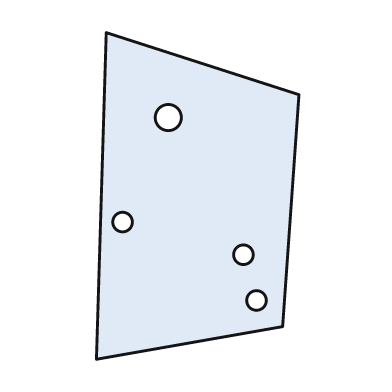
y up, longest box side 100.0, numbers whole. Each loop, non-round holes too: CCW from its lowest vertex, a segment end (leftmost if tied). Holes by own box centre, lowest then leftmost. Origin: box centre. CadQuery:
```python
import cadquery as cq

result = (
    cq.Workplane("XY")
    .moveTo(-31.0, -50.0)
    .lineTo(26.0, -40.0)
    .lineTo(31.0, 31.0)
    .lineTo(-28.0, 50.0)
    .close()
    .moveTo(18.0, -32.0)
    .circle(3.0)
    .moveTo(14.0, -18.0)
    .circle(3.0)
    .moveTo(-23.0, -8.0)
    .circle(3.0)
    .moveTo(-9.0, 24.0)
    .circle(4.0)
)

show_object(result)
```